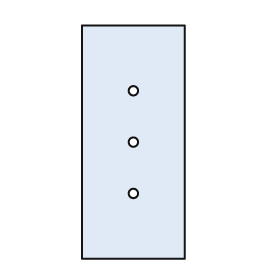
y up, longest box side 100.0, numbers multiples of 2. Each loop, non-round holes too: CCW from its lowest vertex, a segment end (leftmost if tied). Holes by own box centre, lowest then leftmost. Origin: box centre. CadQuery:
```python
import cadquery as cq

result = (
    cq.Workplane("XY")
    .moveTo(-22.0, -50.0)
    .lineTo(22.0, -50.0)
    .lineTo(22.0, 50.0)
    .lineTo(-22.0, 50.0)
    .close()
    .moveTo(0.0, -22.0)
    .circle(2.0)
    .moveTo(0.0, 0.0)
    .circle(2.0)
    .moveTo(0.0, 22.0)
    .circle(2.0)
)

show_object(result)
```